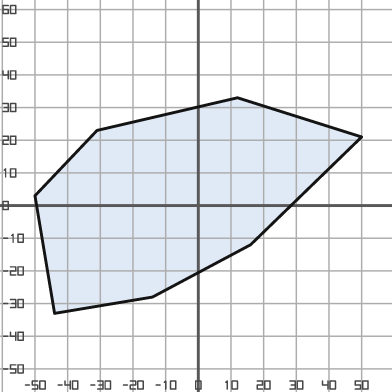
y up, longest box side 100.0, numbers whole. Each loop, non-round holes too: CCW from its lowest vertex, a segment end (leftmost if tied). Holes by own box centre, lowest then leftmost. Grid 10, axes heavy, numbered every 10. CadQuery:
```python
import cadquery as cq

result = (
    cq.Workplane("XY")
    .moveTo(-44.0, -33.0)
    .lineTo(-14.0, -28.0)
    .lineTo(16.0, -12.0)
    .lineTo(50.0, 21.0)
    .lineTo(12.0, 33.0)
    .lineTo(-31.0, 23.0)
    .lineTo(-50.0, 3.0)
    .close()
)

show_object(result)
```